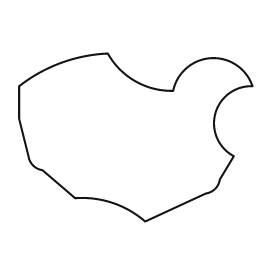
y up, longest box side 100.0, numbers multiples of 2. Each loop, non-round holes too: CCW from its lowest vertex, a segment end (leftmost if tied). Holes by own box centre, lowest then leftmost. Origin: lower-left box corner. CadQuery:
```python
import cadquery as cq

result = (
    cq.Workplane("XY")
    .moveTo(54.0, 0.0)
    .lineTo(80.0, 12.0)
    .threePointArc((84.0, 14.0), (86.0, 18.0))
    .lineTo(92.0, 28.0)
    .threePointArc((84.0, 46.0), (100.0, 58.0))
    .threePointArc((82.0, 70.0), (66.0, 56.0))
    .threePointArc((50.0, 60.0), (38.0, 72.0))
    .threePointArc((18.0, 68.0), (0.0, 58.0))
    .lineTo(0.0, 44.0)
    .lineTo(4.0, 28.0)
    .threePointArc((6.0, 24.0), (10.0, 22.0))
    .lineTo(24.0, 10.0)
    .threePointArc((40.0, 8.0), (54.0, 0.0))
    .close()
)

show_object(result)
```